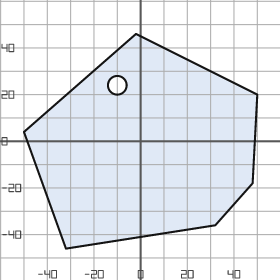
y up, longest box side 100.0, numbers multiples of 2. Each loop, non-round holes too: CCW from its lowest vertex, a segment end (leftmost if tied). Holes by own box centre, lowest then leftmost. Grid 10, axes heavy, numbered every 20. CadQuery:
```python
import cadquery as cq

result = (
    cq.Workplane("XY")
    .moveTo(-32.0, -46.0)
    .lineTo(32.0, -36.0)
    .lineTo(48.0, -18.0)
    .lineTo(50.0, 20.0)
    .lineTo(-2.0, 46.0)
    .lineTo(-50.0, 4.0)
    .close()
    .moveTo(-10.0, 24.0)
    .circle(4.0)
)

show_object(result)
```